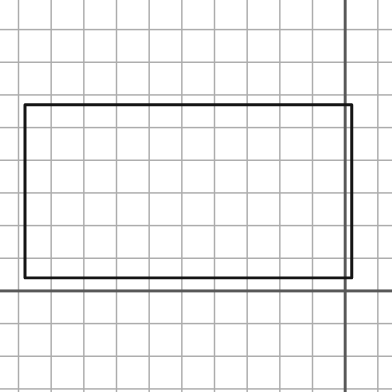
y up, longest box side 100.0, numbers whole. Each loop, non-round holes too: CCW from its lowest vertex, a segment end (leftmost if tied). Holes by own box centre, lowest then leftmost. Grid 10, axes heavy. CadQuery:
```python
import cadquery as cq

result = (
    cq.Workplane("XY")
    .moveTo(-98.0, 4.0)
    .lineTo(2.0, 4.0)
    .lineTo(2.0, 57.0)
    .lineTo(-98.0, 57.0)
    .close()
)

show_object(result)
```